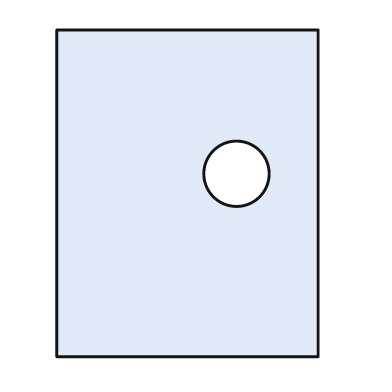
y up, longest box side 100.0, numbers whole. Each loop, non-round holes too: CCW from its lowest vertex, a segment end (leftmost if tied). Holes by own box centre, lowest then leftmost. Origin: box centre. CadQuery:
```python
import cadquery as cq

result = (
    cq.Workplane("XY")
    .moveTo(-40.0, -50.0)
    .lineTo(40.0, -50.0)
    .lineTo(40.0, 50.0)
    .lineTo(-40.0, 50.0)
    .close()
    .moveTo(15.0, 6.0)
    .circle(10.0)
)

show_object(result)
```